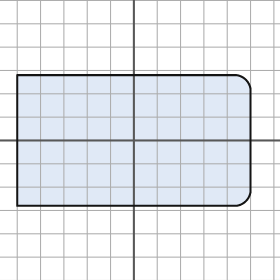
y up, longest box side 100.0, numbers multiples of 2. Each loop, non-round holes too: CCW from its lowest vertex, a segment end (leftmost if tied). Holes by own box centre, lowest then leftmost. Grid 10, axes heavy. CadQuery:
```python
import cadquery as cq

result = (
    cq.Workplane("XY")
    .moveTo(-50.0, -28.0)
    .lineTo(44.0, -28.0)
    .threePointArc((48.0, -26.0), (50.0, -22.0))
    .lineTo(50.0, 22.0)
    .threePointArc((48.0, 26.0), (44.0, 28.0))
    .lineTo(-50.0, 28.0)
    .close()
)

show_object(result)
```